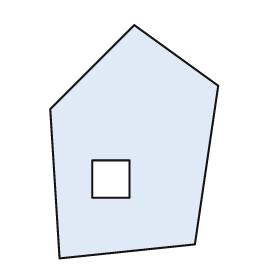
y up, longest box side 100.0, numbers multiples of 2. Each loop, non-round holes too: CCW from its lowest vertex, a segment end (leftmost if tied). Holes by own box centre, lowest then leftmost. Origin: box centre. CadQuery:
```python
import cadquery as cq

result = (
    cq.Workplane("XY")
    .moveTo(-32.0, -50.0)
    .lineTo(26.0, -44.0)
    .lineTo(36.0, 24.0)
    .lineTo(0.0, 50.0)
    .lineTo(-36.0, 14.0)
    .close()
    .moveTo(-18.0, -24.0)
    .lineTo(-2.0, -24.0)
    .lineTo(-2.0, -8.0)
    .lineTo(-18.0, -8.0)
    .close()
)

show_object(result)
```